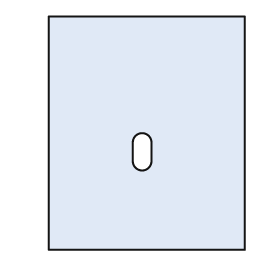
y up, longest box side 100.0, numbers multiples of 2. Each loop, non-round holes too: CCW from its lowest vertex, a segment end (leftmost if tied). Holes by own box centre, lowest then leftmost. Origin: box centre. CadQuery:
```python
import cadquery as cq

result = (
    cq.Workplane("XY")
    .moveTo(-42.0, -50.0)
    .lineTo(42.0, -50.0)
    .lineTo(42.0, 50.0)
    .lineTo(-42.0, 50.0)
    .close()
    .moveTo(-6.0, -12.0)
    .threePointArc((-2.0, -16.0), (2.0, -12.0))
    .lineTo(2.0, -4.0)
    .threePointArc((-2.0, 0.0), (-6.0, -4.0))
    .close()
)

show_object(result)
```